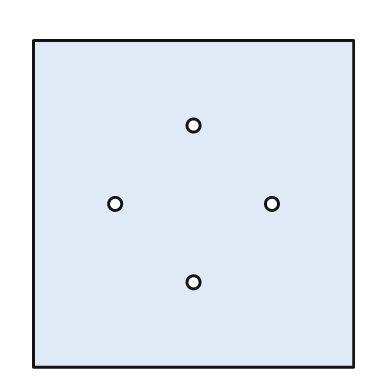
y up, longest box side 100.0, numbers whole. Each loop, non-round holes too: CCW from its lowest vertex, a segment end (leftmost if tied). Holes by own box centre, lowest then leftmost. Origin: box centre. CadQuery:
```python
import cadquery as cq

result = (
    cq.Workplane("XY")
    .moveTo(-49.0, -50.0)
    .lineTo(49.0, -50.0)
    .lineTo(49.0, 50.0)
    .lineTo(-49.0, 50.0)
    .close()
    .moveTo(0.0, -24.0)
    .circle(2.0)
    .moveTo(-24.0, 0.0)
    .circle(2.0)
    .moveTo(24.0, 0.0)
    .circle(2.0)
    .moveTo(0.0, 24.0)
    .circle(2.0)
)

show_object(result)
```